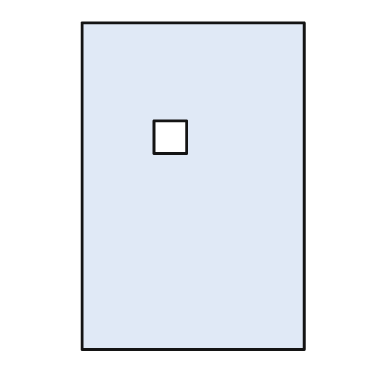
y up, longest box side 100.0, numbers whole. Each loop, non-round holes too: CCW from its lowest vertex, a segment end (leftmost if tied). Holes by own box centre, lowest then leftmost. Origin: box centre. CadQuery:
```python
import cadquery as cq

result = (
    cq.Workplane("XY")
    .moveTo(-34.0, -50.0)
    .lineTo(34.0, -50.0)
    .lineTo(34.0, 50.0)
    .lineTo(-34.0, 50.0)
    .close()
    .moveTo(-12.0, 10.0)
    .lineTo(-2.0, 10.0)
    .lineTo(-2.0, 20.0)
    .lineTo(-12.0, 20.0)
    .close()
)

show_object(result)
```